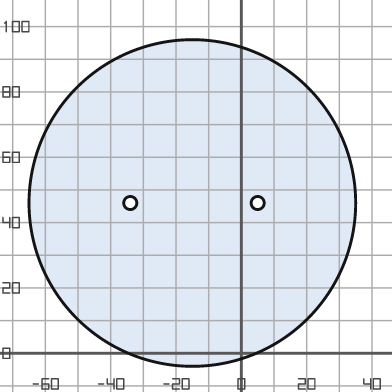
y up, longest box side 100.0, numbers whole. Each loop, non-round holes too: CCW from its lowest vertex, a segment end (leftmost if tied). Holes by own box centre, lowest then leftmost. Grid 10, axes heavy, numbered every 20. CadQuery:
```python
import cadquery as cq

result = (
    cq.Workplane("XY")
    .moveTo(-15.0, 46.0)
    .circle(50.0)
    .moveTo(-34.0, 46.0)
    .circle(2.0)
    .moveTo(5.0, 46.0)
    .circle(2.0)
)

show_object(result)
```